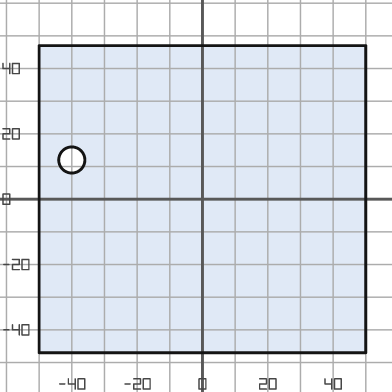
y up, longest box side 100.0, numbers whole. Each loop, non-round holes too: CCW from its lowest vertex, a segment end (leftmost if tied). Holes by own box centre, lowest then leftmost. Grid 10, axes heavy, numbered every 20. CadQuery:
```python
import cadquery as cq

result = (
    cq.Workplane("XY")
    .moveTo(-50.0, -47.0)
    .lineTo(50.0, -47.0)
    .lineTo(50.0, 47.0)
    .lineTo(-50.0, 47.0)
    .close()
    .moveTo(-40.0, 12.0)
    .circle(4.0)
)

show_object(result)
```